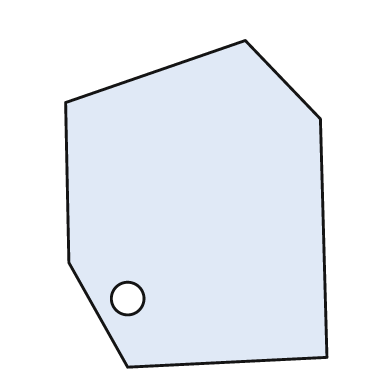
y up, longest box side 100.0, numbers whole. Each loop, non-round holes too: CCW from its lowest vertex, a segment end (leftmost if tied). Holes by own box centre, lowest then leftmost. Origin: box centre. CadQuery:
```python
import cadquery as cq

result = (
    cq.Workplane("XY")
    .moveTo(-21.0, -50.0)
    .lineTo(40.0, -47.0)
    .lineTo(38.0, 26.0)
    .lineTo(15.0, 50.0)
    .lineTo(-40.0, 31.0)
    .lineTo(-39.0, -18.0)
    .close()
    .moveTo(-21.0, -29.0)
    .circle(5.0)
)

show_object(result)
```